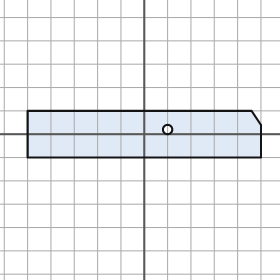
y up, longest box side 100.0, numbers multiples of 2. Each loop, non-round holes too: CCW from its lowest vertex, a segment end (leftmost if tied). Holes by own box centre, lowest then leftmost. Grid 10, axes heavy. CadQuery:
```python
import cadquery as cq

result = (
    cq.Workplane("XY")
    .moveTo(-50.0, -10.0)
    .lineTo(50.0, -10.0)
    .lineTo(50.0, 4.0)
    .lineTo(46.0, 10.0)
    .lineTo(-50.0, 10.0)
    .close()
    .moveTo(10.0, 2.0)
    .circle(2.0)
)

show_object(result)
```